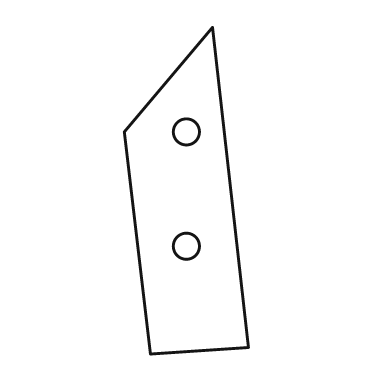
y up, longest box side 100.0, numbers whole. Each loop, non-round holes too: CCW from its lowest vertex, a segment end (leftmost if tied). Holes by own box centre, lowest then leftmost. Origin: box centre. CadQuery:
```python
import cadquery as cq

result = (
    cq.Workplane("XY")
    .moveTo(-11.0, -50.0)
    .lineTo(19.0, -48.0)
    .lineTo(8.0, 50.0)
    .lineTo(-19.0, 18.0)
    .close()
    .moveTo(0.0, -17.0)
    .circle(4.0)
    .moveTo(0.0, 18.0)
    .circle(4.0)
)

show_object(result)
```